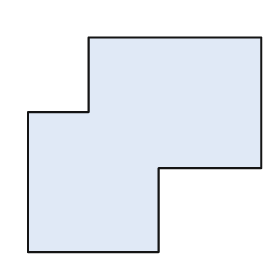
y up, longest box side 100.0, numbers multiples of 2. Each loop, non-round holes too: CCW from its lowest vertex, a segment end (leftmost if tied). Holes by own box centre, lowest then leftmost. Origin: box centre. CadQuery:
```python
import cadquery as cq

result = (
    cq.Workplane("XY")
    .moveTo(-50.0, -46.0)
    .lineTo(6.0, -46.0)
    .lineTo(6.0, -10.0)
    .lineTo(50.0, -10.0)
    .lineTo(50.0, 46.0)
    .lineTo(-24.0, 46.0)
    .lineTo(-24.0, 14.0)
    .lineTo(-50.0, 14.0)
    .close()
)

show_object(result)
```